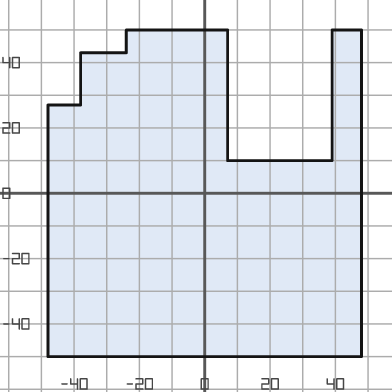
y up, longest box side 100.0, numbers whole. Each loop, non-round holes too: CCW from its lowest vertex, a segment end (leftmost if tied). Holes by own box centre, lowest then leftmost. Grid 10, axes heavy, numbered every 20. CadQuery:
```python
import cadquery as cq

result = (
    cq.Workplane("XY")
    .moveTo(-48.0, -50.0)
    .lineTo(48.0, -50.0)
    .lineTo(48.0, 50.0)
    .lineTo(39.0, 50.0)
    .lineTo(39.0, 10.0)
    .lineTo(7.0, 10.0)
    .lineTo(7.0, 50.0)
    .lineTo(-24.0, 50.0)
    .lineTo(-24.0, 43.0)
    .lineTo(-38.0, 43.0)
    .lineTo(-38.0, 27.0)
    .lineTo(-48.0, 27.0)
    .close()
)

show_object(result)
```